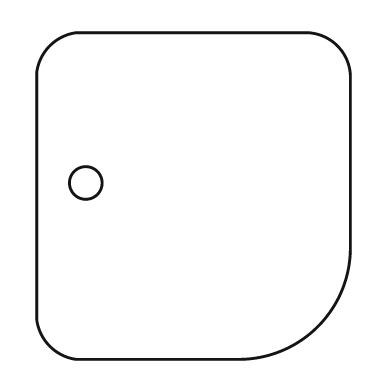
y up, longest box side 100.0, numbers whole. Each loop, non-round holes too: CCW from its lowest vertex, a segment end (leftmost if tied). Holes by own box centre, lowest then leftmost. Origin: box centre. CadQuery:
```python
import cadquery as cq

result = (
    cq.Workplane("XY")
    .moveTo(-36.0, -50.0)
    .lineTo(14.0, -50.0)
    .threePointArc((38.0, -40.0), (48.0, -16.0))
    .lineTo(48.0, 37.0)
    .threePointArc((44.0, 46.0), (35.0, 50.0))
    .lineTo(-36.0, 50.0)
    .threePointArc((-44.0, 46.0), (-48.0, 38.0))
    .lineTo(-48.0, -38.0)
    .threePointArc((-44.0, -46.0), (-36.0, -50.0))
    .close()
    .moveTo(-33.0, 4.0)
    .circle(5.0)
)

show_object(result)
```